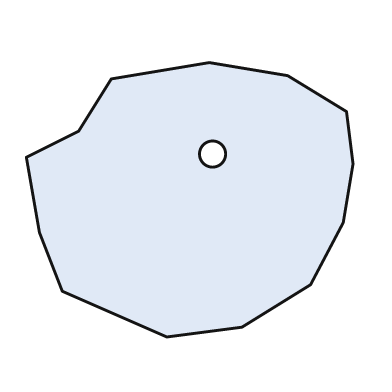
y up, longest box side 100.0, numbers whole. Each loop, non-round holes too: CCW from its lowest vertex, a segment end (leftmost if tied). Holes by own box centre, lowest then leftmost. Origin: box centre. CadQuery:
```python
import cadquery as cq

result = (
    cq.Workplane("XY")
    .moveTo(-7.0, -42.0)
    .lineTo(16.0, -39.0)
    .lineTo(37.0, -26.0)
    .lineTo(47.0, -7.0)
    .lineTo(50.0, 11.0)
    .lineTo(48.0, 27.0)
    .lineTo(30.0, 38.0)
    .lineTo(6.0, 42.0)
    .lineTo(-24.0, 37.0)
    .lineTo(-34.0, 21.0)
    .lineTo(-50.0, 13.0)
    .lineTo(-46.0, -10.0)
    .lineTo(-39.0, -28.0)
    .close()
    .moveTo(7.0, 14.0)
    .circle(4.0)
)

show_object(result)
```